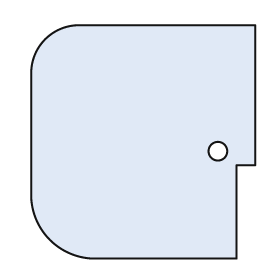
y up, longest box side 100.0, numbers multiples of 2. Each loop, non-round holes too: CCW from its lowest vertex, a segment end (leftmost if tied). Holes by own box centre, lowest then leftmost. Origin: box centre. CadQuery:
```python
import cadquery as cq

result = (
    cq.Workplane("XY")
    .moveTo(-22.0, -50.0)
    .lineTo(40.0, -50.0)
    .lineTo(40.0, -10.0)
    .lineTo(48.0, -10.0)
    .lineTo(48.0, 50.0)
    .lineTo(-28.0, 50.0)
    .threePointArc((-42.0, 44.0), (-48.0, 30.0))
    .lineTo(-48.0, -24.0)
    .threePointArc((-40.0, -42.0), (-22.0, -50.0))
    .close()
    .moveTo(32.0, -4.0)
    .circle(4.0)
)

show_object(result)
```